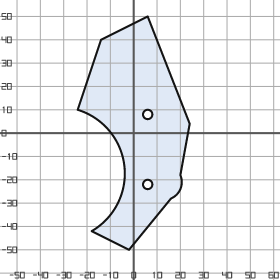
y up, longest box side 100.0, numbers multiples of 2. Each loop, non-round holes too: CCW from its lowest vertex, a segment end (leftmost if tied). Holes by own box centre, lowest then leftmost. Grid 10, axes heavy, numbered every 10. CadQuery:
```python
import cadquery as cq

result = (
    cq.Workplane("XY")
    .moveTo(-2.0, -50.0)
    .lineTo(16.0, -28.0)
    .threePointArc((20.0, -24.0), (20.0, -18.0))
    .lineTo(24.0, 4.0)
    .lineTo(6.0, 50.0)
    .lineTo(-14.0, 40.0)
    .lineTo(-24.0, 10.0)
    .threePointArc((-4.0, -14.0), (-18.0, -42.0))
    .close()
    .moveTo(6.0, -22.0)
    .circle(2.0)
    .moveTo(6.0, 8.0)
    .circle(2.0)
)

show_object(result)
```